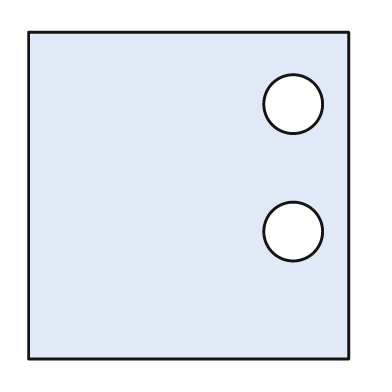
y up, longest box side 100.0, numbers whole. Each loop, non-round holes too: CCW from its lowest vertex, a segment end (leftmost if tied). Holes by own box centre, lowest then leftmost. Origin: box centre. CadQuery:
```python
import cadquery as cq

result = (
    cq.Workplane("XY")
    .moveTo(-49.0, -50.0)
    .lineTo(49.0, -50.0)
    .lineTo(49.0, 50.0)
    .lineTo(-49.0, 50.0)
    .close()
    .moveTo(32.0, -11.0)
    .circle(9.0)
    .moveTo(32.0, 28.0)
    .circle(9.0)
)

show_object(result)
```